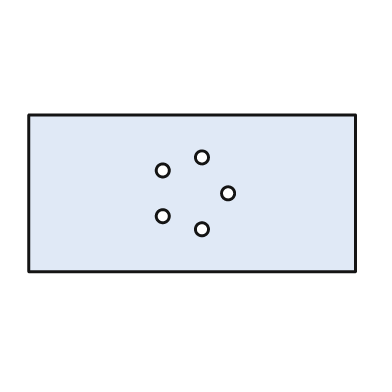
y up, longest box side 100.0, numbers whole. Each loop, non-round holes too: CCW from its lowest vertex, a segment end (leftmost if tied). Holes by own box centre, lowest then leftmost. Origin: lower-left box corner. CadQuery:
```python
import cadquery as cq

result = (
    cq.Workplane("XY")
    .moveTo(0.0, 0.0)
    .lineTo(100.0, 0.0)
    .lineTo(100.0, 48.0)
    .lineTo(0.0, 48.0)
    .close()
    .moveTo(53.0, 13.0)
    .circle(2.0)
    .moveTo(41.0, 17.0)
    .circle(2.0)
    .moveTo(61.0, 24.0)
    .circle(2.0)
    .moveTo(41.0, 31.0)
    .circle(2.0)
    .moveTo(53.0, 35.0)
    .circle(2.0)
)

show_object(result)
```